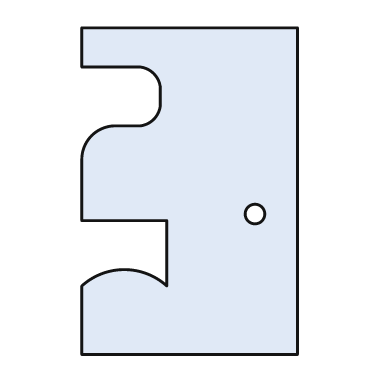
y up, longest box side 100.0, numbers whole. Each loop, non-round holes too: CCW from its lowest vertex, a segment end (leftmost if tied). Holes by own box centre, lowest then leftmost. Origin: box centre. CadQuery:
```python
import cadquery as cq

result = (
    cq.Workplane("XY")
    .moveTo(-33.0, -50.0)
    .lineTo(33.0, -50.0)
    .lineTo(33.0, 50.0)
    .lineTo(-33.0, 50.0)
    .lineTo(-33.0, 38.0)
    .lineTo(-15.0, 38.0)
    .threePointArc((-11.0, 36.0), (-9.0, 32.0))
    .lineTo(-9.0, 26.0)
    .threePointArc((-11.0, 22.0), (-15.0, 20.0))
    .lineTo(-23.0, 20.0)
    .threePointArc((-30.0, 17.0), (-33.0, 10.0))
    .lineTo(-33.0, -9.0)
    .lineTo(-7.0, -9.0)
    .lineTo(-7.0, -29.0)
    .threePointArc((-20.0, -24.0), (-33.0, -29.0))
    .close()
    .moveTo(20.0, -7.0)
    .circle(3.0)
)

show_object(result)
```